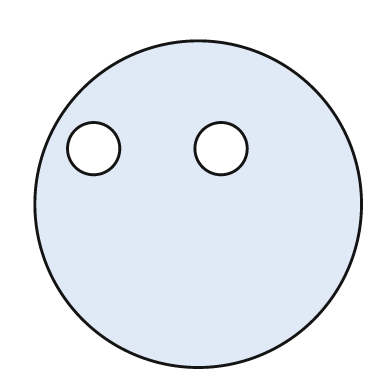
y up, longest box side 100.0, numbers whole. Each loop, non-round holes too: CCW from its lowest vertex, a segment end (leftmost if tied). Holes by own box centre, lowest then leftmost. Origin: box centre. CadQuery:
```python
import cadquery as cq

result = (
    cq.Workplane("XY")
    .moveTo(0.0, 0.0)
    .circle(50.0)
    .moveTo(-32.0, 17.0)
    .circle(8.0)
    .moveTo(7.0, 17.0)
    .circle(8.0)
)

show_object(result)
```